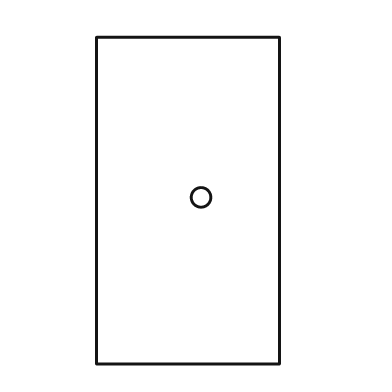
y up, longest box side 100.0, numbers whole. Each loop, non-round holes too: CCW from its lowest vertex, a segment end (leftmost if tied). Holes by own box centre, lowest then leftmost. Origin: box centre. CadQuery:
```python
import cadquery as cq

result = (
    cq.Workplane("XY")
    .moveTo(-28.0, -50.0)
    .lineTo(28.0, -50.0)
    .lineTo(28.0, 50.0)
    .lineTo(-28.0, 50.0)
    .close()
    .moveTo(4.0, 1.0)
    .circle(3.0)
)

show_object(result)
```